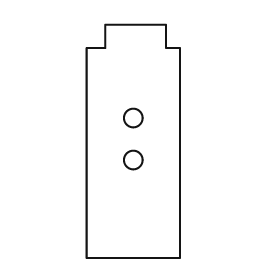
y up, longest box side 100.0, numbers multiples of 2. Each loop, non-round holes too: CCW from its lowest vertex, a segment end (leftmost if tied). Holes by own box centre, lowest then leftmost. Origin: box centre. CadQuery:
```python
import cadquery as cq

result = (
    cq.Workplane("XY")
    .moveTo(-20.0, -50.0)
    .lineTo(20.0, -50.0)
    .lineTo(20.0, 40.0)
    .lineTo(14.0, 40.0)
    .lineTo(14.0, 50.0)
    .lineTo(-12.0, 50.0)
    .lineTo(-12.0, 40.0)
    .lineTo(-20.0, 40.0)
    .close()
    .moveTo(0.0, -8.0)
    .circle(4.0)
    .moveTo(0.0, 10.0)
    .circle(4.0)
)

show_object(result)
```